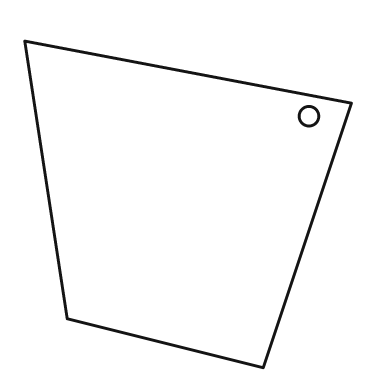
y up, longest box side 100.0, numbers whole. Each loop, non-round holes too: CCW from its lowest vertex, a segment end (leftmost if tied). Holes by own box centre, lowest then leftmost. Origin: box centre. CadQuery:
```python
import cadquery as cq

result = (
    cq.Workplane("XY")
    .moveTo(23.0, -50.0)
    .lineTo(50.0, 31.0)
    .lineTo(-50.0, 50.0)
    .lineTo(-37.0, -35.0)
    .close()
    .moveTo(37.0, 27.0)
    .circle(3.0)
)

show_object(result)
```